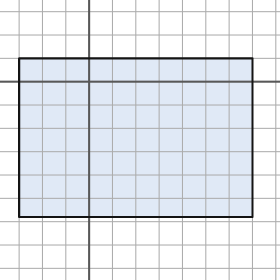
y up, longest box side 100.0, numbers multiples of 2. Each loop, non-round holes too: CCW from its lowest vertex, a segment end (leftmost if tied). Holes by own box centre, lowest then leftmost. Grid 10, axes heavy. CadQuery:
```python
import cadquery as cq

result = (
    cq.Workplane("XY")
    .moveTo(-30.0, -58.0)
    .lineTo(70.0, -58.0)
    .lineTo(70.0, 10.0)
    .lineTo(-30.0, 10.0)
    .close()
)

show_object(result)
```